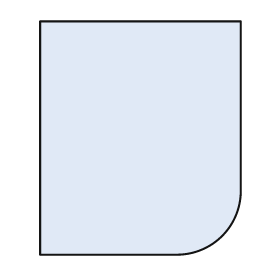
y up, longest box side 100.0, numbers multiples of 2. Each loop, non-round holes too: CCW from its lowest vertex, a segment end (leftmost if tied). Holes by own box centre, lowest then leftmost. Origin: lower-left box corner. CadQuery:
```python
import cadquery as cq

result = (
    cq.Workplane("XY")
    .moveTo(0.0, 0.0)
    .lineTo(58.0, 0.0)
    .threePointArc((78.0, 8.0), (86.0, 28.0))
    .lineTo(86.0, 100.0)
    .lineTo(0.0, 100.0)
    .close()
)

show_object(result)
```